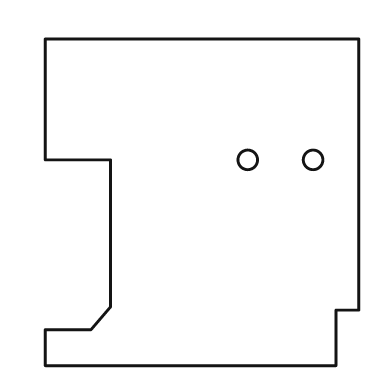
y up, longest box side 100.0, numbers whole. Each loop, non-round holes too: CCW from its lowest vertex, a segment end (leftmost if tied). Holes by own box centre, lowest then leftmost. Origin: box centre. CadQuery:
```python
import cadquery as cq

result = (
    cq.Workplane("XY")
    .moveTo(-48.0, -50.0)
    .lineTo(41.0, -50.0)
    .lineTo(41.0, -33.0)
    .lineTo(48.0, -33.0)
    .lineTo(48.0, 50.0)
    .lineTo(-48.0, 50.0)
    .lineTo(-48.0, 13.0)
    .lineTo(-28.0, 13.0)
    .lineTo(-28.0, -32.0)
    .lineTo(-34.0, -39.0)
    .lineTo(-48.0, -39.0)
    .close()
    .moveTo(14.0, 13.0)
    .circle(3.0)
    .moveTo(34.0, 13.0)
    .circle(3.0)
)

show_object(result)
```